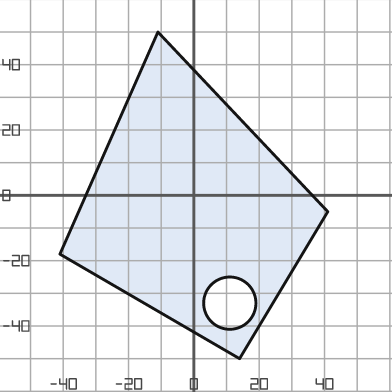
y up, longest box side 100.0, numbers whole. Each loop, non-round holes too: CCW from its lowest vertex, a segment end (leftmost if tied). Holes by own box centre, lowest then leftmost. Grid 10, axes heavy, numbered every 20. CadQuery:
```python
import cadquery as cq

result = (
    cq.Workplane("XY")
    .moveTo(14.0, -50.0)
    .lineTo(41.0, -5.0)
    .lineTo(-11.0, 50.0)
    .lineTo(-41.0, -18.0)
    .close()
    .moveTo(11.0, -33.0)
    .circle(8.0)
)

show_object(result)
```